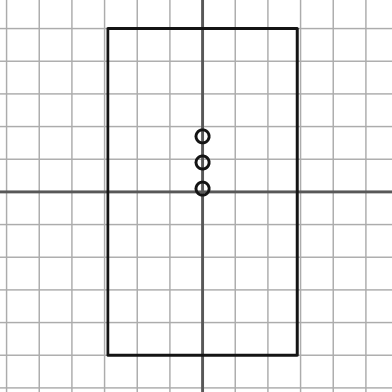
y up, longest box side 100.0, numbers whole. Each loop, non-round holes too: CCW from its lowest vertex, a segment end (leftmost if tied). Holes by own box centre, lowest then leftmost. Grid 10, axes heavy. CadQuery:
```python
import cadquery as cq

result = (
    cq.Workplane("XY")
    .moveTo(-29.0, -50.0)
    .lineTo(29.0, -50.0)
    .lineTo(29.0, 50.0)
    .lineTo(-29.0, 50.0)
    .close()
    .moveTo(0.0, 1.0)
    .circle(2.0)
    .moveTo(0.0, 9.0)
    .circle(2.0)
    .moveTo(0.0, 17.0)
    .circle(2.0)
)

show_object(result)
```